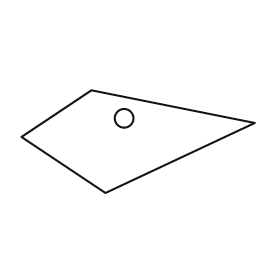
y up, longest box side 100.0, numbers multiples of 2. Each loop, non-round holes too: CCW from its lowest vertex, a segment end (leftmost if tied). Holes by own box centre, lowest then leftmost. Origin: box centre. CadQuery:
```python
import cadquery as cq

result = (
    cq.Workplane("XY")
    .moveTo(-14.0, -22.0)
    .lineTo(50.0, 8.0)
    .lineTo(-20.0, 22.0)
    .lineTo(-50.0, 2.0)
    .close()
    .moveTo(-6.0, 10.0)
    .circle(4.0)
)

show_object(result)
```